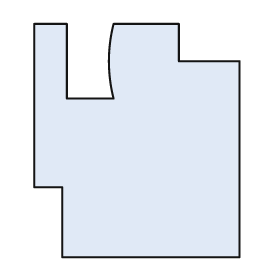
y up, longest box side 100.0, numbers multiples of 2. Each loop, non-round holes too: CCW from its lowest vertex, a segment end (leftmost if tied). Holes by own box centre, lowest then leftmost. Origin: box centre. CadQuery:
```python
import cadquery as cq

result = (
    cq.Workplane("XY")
    .moveTo(-32.0, -50.0)
    .lineTo(44.0, -50.0)
    .lineTo(44.0, 34.0)
    .lineTo(18.0, 34.0)
    .lineTo(18.0, 50.0)
    .lineTo(-10.0, 50.0)
    .threePointArc((-12.0, 34.0), (-10.0, 18.0))
    .lineTo(-30.0, 18.0)
    .lineTo(-30.0, 50.0)
    .lineTo(-44.0, 50.0)
    .lineTo(-44.0, -20.0)
    .lineTo(-32.0, -20.0)
    .close()
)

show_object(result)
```